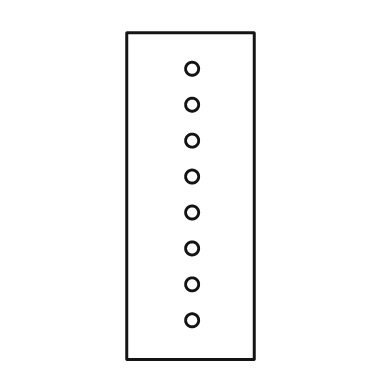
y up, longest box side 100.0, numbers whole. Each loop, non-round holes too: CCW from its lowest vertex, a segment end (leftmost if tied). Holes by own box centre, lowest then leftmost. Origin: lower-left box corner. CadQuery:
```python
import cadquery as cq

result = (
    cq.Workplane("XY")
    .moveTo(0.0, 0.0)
    .lineTo(39.0, 0.0)
    .lineTo(39.0, 100.0)
    .lineTo(0.0, 100.0)
    .close()
    .moveTo(20.0, 12.0)
    .circle(2.0)
    .moveTo(20.0, 23.0)
    .circle(2.0)
    .moveTo(20.0, 34.0)
    .circle(2.0)
    .moveTo(20.0, 45.0)
    .circle(2.0)
    .moveTo(20.0, 56.0)
    .circle(2.0)
    .moveTo(20.0, 67.0)
    .circle(2.0)
    .moveTo(20.0, 78.0)
    .circle(2.0)
    .moveTo(20.0, 89.0)
    .circle(2.0)
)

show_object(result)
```